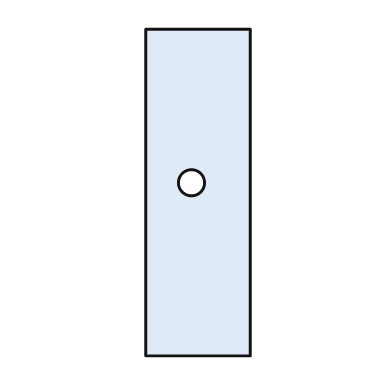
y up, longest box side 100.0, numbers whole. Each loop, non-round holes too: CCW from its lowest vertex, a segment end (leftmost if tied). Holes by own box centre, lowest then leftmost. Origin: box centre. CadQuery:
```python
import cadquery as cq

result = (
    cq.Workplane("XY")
    .moveTo(-16.0, -50.0)
    .lineTo(16.0, -50.0)
    .lineTo(16.0, 50.0)
    .lineTo(-16.0, 50.0)
    .close()
    .moveTo(-2.0, 3.0)
    .circle(4.0)
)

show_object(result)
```